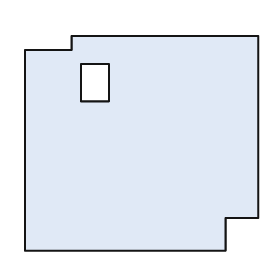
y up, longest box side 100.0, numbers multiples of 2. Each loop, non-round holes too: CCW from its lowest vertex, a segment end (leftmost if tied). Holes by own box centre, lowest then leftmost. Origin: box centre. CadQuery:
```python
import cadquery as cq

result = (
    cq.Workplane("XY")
    .moveTo(-50.0, -46.0)
    .lineTo(36.0, -46.0)
    .lineTo(36.0, -32.0)
    .lineTo(50.0, -32.0)
    .lineTo(50.0, 46.0)
    .lineTo(-30.0, 46.0)
    .lineTo(-30.0, 40.0)
    .lineTo(-50.0, 40.0)
    .close()
    .moveTo(-26.0, 18.0)
    .lineTo(-14.0, 18.0)
    .lineTo(-14.0, 34.0)
    .lineTo(-26.0, 34.0)
    .close()
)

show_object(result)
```